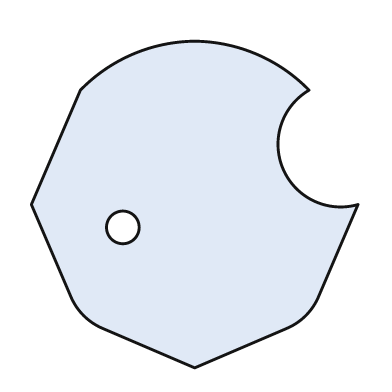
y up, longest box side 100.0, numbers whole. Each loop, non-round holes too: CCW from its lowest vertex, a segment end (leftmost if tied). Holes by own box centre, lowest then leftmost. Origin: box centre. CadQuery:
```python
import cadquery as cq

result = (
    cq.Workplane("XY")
    .moveTo(0.0, -50.0)
    .lineTo(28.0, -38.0)
    .threePointArc((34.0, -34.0), (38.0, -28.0))
    .lineTo(50.0, 0.0)
    .threePointArc((27.0, 11.0), (35.0, 35.0))
    .threePointArc((19.0, 46.0), (0.0, 50.0))
    .threePointArc((-19.0, 46.0), (-35.0, 35.0))
    .lineTo(-50.0, 0.0)
    .lineTo(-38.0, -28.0)
    .threePointArc((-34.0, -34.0), (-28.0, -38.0))
    .close()
    .moveTo(-22.0, -7.0)
    .circle(5.0)
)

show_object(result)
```